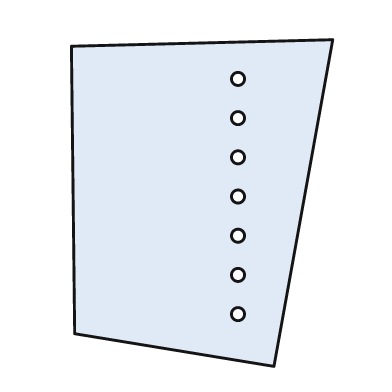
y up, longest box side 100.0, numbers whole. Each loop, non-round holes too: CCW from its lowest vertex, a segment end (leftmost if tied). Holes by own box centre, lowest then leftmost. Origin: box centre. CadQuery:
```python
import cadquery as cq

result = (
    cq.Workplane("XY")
    .moveTo(22.0, -50.0)
    .lineTo(40.0, 50.0)
    .lineTo(-40.0, 48.0)
    .lineTo(-39.0, -40.0)
    .close()
    .moveTo(11.0, -34.0)
    .circle(2.0)
    .moveTo(11.0, -22.0)
    .circle(2.0)
    .moveTo(11.0, -10.0)
    .circle(2.0)
    .moveTo(11.0, 2.0)
    .circle(2.0)
    .moveTo(11.0, 14.0)
    .circle(2.0)
    .moveTo(11.0, 26.0)
    .circle(2.0)
    .moveTo(11.0, 38.0)
    .circle(2.0)
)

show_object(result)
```